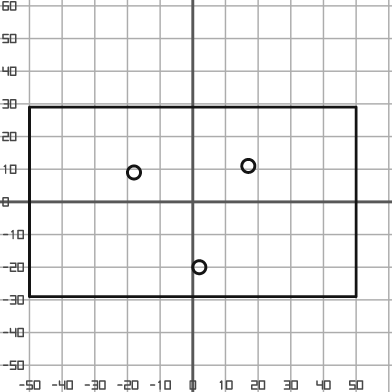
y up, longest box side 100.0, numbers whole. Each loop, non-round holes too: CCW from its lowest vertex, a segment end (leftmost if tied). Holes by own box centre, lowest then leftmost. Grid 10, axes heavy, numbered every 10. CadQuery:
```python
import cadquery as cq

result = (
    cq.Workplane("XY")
    .moveTo(-50.0, -29.0)
    .lineTo(50.0, -29.0)
    .lineTo(50.0, 29.0)
    .lineTo(-50.0, 29.0)
    .close()
    .moveTo(2.0, -20.0)
    .circle(2.0)
    .moveTo(-18.0, 9.0)
    .circle(2.0)
    .moveTo(17.0, 11.0)
    .circle(2.0)
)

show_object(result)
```